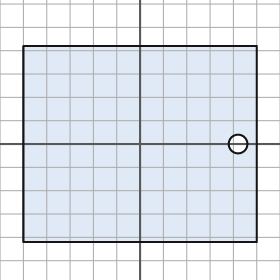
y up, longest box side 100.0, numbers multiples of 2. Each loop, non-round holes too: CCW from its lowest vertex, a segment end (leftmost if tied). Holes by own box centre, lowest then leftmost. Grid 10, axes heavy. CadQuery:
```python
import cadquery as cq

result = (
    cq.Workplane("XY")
    .moveTo(-50.0, -42.0)
    .lineTo(50.0, -42.0)
    .lineTo(50.0, 42.0)
    .lineTo(-50.0, 42.0)
    .close()
    .moveTo(42.0, 0.0)
    .circle(4.0)
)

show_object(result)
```